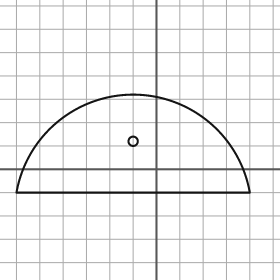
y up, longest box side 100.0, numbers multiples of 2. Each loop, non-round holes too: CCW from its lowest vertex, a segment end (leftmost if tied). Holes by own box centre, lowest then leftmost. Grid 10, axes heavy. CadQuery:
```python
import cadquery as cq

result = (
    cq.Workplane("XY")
    .moveTo(-60.0, -10.0)
    .lineTo(40.0, -10.0)
    .threePointArc((-10.0, 32.0), (-60.0, -10.0))
    .close()
    .moveTo(-10.0, 12.0)
    .circle(2.0)
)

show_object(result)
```